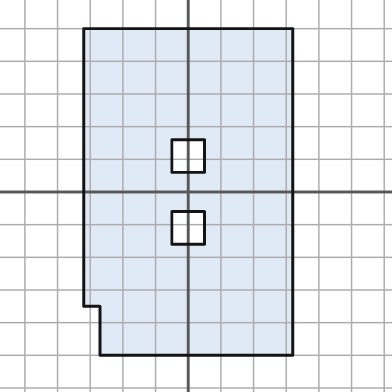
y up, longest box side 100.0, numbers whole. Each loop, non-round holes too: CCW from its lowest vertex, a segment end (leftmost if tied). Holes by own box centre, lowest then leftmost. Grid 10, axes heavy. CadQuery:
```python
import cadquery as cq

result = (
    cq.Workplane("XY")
    .moveTo(-27.0, -50.0)
    .lineTo(32.0, -50.0)
    .lineTo(32.0, 50.0)
    .lineTo(-32.0, 50.0)
    .lineTo(-32.0, -35.0)
    .lineTo(-27.0, -35.0)
    .close()
    .moveTo(-5.0, -16.0)
    .lineTo(5.0, -16.0)
    .lineTo(5.0, -6.0)
    .lineTo(-5.0, -6.0)
    .close()
    .moveTo(-5.0, 6.0)
    .lineTo(5.0, 6.0)
    .lineTo(5.0, 16.0)
    .lineTo(-5.0, 16.0)
    .close()
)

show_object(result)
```